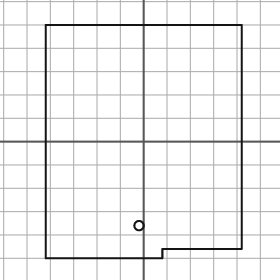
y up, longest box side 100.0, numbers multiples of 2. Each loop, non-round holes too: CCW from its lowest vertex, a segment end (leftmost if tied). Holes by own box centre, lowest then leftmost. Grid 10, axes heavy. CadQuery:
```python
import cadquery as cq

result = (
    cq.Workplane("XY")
    .moveTo(-42.0, -50.0)
    .lineTo(8.0, -50.0)
    .lineTo(8.0, -46.0)
    .lineTo(42.0, -46.0)
    .lineTo(42.0, 50.0)
    .lineTo(-42.0, 50.0)
    .close()
    .moveTo(-2.0, -36.0)
    .circle(2.0)
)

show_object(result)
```